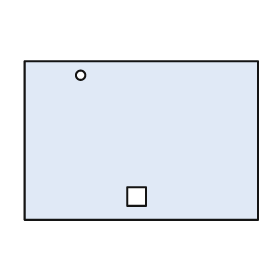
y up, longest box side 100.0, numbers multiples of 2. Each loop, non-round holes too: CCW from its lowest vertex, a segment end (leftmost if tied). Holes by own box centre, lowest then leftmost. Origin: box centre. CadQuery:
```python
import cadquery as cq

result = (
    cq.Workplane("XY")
    .moveTo(-50.0, -34.0)
    .lineTo(50.0, -34.0)
    .lineTo(50.0, 34.0)
    .lineTo(-50.0, 34.0)
    .close()
    .moveTo(-6.0, -28.0)
    .lineTo(2.0, -28.0)
    .lineTo(2.0, -20.0)
    .lineTo(-6.0, -20.0)
    .close()
    .moveTo(-26.0, 28.0)
    .circle(2.0)
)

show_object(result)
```